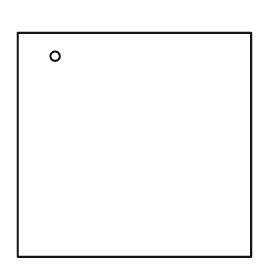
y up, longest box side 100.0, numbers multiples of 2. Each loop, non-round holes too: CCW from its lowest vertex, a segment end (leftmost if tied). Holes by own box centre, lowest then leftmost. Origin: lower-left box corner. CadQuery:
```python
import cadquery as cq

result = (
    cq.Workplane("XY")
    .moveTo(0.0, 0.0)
    .lineTo(100.0, 0.0)
    .lineTo(100.0, 96.0)
    .lineTo(0.0, 96.0)
    .close()
    .moveTo(16.0, 86.0)
    .circle(2.0)
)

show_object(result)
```